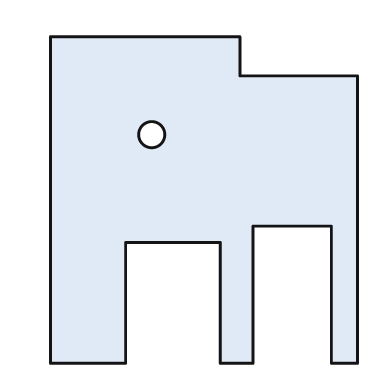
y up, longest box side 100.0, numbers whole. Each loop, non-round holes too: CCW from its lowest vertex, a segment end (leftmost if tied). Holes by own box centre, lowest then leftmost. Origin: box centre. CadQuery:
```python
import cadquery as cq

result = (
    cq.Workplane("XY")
    .moveTo(-47.0, -50.0)
    .lineTo(-24.0, -50.0)
    .lineTo(-24.0, -13.0)
    .lineTo(5.0, -13.0)
    .lineTo(5.0, -50.0)
    .lineTo(15.0, -50.0)
    .lineTo(15.0, -8.0)
    .lineTo(39.0, -8.0)
    .lineTo(39.0, -50.0)
    .lineTo(47.0, -50.0)
    .lineTo(47.0, 38.0)
    .lineTo(11.0, 38.0)
    .lineTo(11.0, 50.0)
    .lineTo(-47.0, 50.0)
    .close()
    .moveTo(-16.0, 20.0)
    .circle(4.0)
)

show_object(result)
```